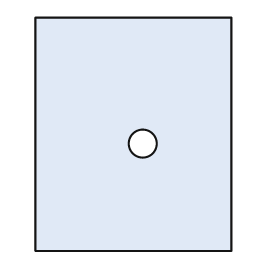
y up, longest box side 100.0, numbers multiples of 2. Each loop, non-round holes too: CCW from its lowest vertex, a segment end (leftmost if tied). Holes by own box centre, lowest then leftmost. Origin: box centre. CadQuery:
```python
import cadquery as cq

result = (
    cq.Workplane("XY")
    .moveTo(-42.0, -50.0)
    .lineTo(42.0, -50.0)
    .lineTo(42.0, 50.0)
    .lineTo(-42.0, 50.0)
    .close()
    .moveTo(4.0, -4.0)
    .circle(6.0)
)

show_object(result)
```